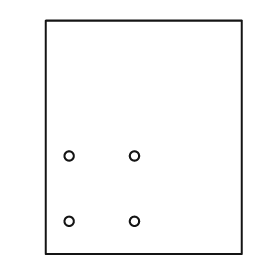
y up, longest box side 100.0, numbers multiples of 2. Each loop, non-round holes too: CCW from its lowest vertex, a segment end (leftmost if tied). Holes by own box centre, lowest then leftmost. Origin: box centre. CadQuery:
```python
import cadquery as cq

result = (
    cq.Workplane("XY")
    .moveTo(-42.0, -50.0)
    .lineTo(42.0, -50.0)
    .lineTo(42.0, 50.0)
    .lineTo(-42.0, 50.0)
    .close()
    .moveTo(-32.0, -36.0)
    .circle(2.0)
    .moveTo(-4.0, -36.0)
    .circle(2.0)
    .moveTo(-32.0, -8.0)
    .circle(2.0)
    .moveTo(-4.0, -8.0)
    .circle(2.0)
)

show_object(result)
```